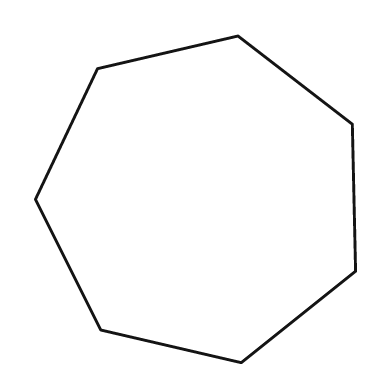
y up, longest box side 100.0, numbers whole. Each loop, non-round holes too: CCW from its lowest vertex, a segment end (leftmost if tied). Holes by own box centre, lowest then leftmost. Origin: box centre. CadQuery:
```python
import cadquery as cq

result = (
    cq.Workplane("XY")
    .moveTo(14.0, -50.0)
    .lineTo(49.0, -22.0)
    .lineTo(48.0, 23.0)
    .lineTo(13.0, 50.0)
    .lineTo(-30.0, 40.0)
    .lineTo(-49.0, 0.0)
    .lineTo(-29.0, -40.0)
    .close()
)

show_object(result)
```